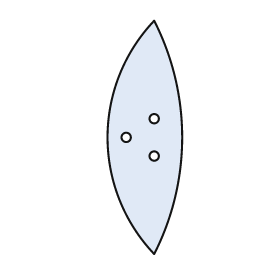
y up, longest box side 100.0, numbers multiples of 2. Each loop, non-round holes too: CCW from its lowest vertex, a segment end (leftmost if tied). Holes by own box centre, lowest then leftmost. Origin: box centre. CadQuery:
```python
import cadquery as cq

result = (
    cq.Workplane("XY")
    .moveTo(4.0, -50.0)
    .threePointArc((16.0, 0.0), (4.0, 50.0))
    .threePointArc((-16.0, 0.0), (4.0, -50.0))
    .close()
    .moveTo(4.0, -8.0)
    .circle(2.0)
    .moveTo(-8.0, 0.0)
    .circle(2.0)
    .moveTo(4.0, 8.0)
    .circle(2.0)
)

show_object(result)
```